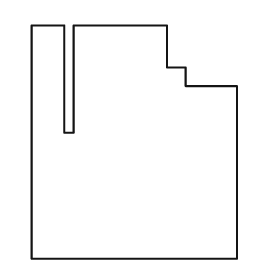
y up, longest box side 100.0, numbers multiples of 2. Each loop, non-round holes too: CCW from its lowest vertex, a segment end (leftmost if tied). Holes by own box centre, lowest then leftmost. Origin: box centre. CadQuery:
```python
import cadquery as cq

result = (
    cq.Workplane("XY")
    .moveTo(-44.0, -50.0)
    .lineTo(44.0, -50.0)
    .lineTo(44.0, 24.0)
    .lineTo(22.0, 24.0)
    .lineTo(22.0, 32.0)
    .lineTo(14.0, 32.0)
    .lineTo(14.0, 50.0)
    .lineTo(-26.0, 50.0)
    .lineTo(-26.0, 4.0)
    .lineTo(-30.0, 4.0)
    .lineTo(-30.0, 50.0)
    .lineTo(-44.0, 50.0)
    .close()
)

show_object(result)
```